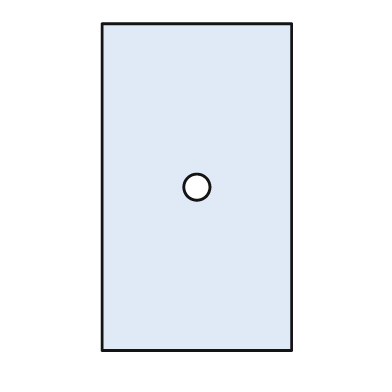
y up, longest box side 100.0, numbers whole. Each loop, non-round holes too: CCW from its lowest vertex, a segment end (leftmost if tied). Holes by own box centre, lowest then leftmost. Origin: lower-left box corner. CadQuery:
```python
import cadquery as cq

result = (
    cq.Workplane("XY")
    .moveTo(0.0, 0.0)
    .lineTo(58.0, 0.0)
    .lineTo(58.0, 100.0)
    .lineTo(0.0, 100.0)
    .close()
    .moveTo(29.0, 50.0)
    .circle(4.0)
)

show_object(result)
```